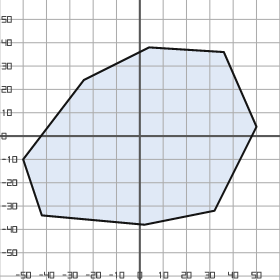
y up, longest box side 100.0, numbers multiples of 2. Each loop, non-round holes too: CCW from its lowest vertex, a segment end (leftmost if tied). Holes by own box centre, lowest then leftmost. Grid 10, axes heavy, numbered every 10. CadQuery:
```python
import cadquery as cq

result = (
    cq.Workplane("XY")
    .moveTo(2.0, -38.0)
    .lineTo(32.0, -32.0)
    .lineTo(50.0, 4.0)
    .lineTo(36.0, 36.0)
    .lineTo(4.0, 38.0)
    .lineTo(-24.0, 24.0)
    .lineTo(-50.0, -10.0)
    .lineTo(-42.0, -34.0)
    .close()
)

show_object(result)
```